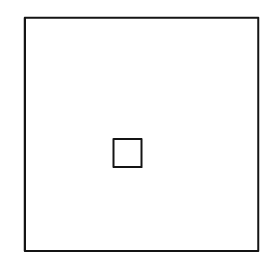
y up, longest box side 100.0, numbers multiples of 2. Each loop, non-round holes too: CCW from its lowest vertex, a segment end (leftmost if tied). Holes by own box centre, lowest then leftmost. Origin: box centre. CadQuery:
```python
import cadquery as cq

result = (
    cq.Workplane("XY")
    .moveTo(-50.0, -50.0)
    .lineTo(50.0, -50.0)
    .lineTo(50.0, 50.0)
    .lineTo(-50.0, 50.0)
    .close()
    .moveTo(-12.0, -14.0)
    .lineTo(0.0, -14.0)
    .lineTo(0.0, -2.0)
    .lineTo(-12.0, -2.0)
    .close()
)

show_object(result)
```